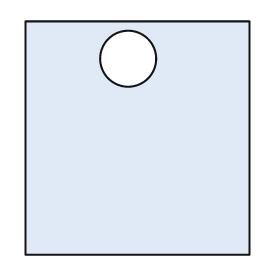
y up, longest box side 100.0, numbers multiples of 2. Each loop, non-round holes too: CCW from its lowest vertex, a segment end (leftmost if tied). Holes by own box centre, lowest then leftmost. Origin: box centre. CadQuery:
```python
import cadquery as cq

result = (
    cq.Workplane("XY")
    .moveTo(-48.0, -50.0)
    .lineTo(48.0, -50.0)
    .lineTo(48.0, 50.0)
    .lineTo(-48.0, 50.0)
    .close()
    .moveTo(-4.0, 34.0)
    .circle(12.0)
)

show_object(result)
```